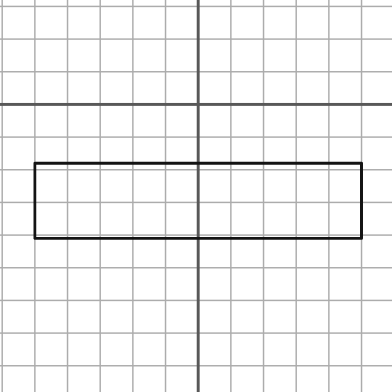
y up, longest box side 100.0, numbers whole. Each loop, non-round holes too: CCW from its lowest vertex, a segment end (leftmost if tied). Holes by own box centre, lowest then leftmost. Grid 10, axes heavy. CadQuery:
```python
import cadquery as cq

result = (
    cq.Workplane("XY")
    .moveTo(-50.0, -41.0)
    .lineTo(50.0, -41.0)
    .lineTo(50.0, -18.0)
    .lineTo(-50.0, -18.0)
    .close()
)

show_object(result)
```